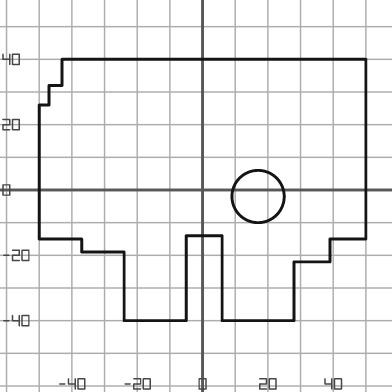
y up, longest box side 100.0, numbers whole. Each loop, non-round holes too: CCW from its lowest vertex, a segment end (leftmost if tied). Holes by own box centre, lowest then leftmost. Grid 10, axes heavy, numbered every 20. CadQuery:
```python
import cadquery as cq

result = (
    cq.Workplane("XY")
    .moveTo(-24.0, -40.0)
    .lineTo(-5.0, -40.0)
    .lineTo(-5.0, -14.0)
    .lineTo(6.0, -14.0)
    .lineTo(6.0, -40.0)
    .lineTo(28.0, -40.0)
    .lineTo(28.0, -22.0)
    .lineTo(39.0, -22.0)
    .lineTo(39.0, -15.0)
    .lineTo(50.0, -15.0)
    .lineTo(50.0, 40.0)
    .lineTo(-43.0, 40.0)
    .lineTo(-43.0, 32.0)
    .lineTo(-47.0, 32.0)
    .lineTo(-47.0, 26.0)
    .lineTo(-50.0, 26.0)
    .lineTo(-50.0, -15.0)
    .lineTo(-37.0, -15.0)
    .lineTo(-37.0, -19.0)
    .lineTo(-24.0, -19.0)
    .close()
    .moveTo(17.0, -2.0)
    .circle(8.0)
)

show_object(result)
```